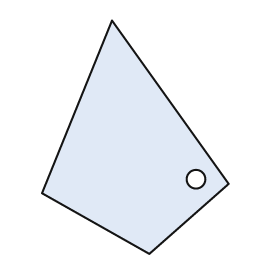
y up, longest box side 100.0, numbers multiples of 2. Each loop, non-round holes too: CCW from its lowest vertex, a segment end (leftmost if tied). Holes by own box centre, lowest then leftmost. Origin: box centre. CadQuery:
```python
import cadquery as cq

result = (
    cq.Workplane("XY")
    .moveTo(6.0, -50.0)
    .lineTo(40.0, -20.0)
    .lineTo(-10.0, 50.0)
    .lineTo(-40.0, -24.0)
    .close()
    .moveTo(26.0, -18.0)
    .circle(4.0)
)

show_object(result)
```